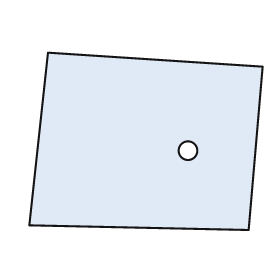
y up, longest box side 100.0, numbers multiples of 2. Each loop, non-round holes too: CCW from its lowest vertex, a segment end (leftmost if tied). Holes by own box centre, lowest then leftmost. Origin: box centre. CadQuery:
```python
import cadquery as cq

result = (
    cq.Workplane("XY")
    .moveTo(44.0, -38.0)
    .lineTo(50.0, 32.0)
    .lineTo(-42.0, 38.0)
    .lineTo(-50.0, -36.0)
    .close()
    .moveTo(18.0, -4.0)
    .circle(4.0)
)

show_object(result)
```